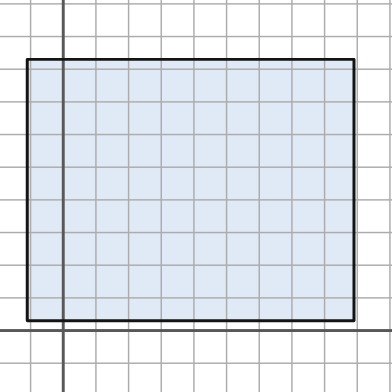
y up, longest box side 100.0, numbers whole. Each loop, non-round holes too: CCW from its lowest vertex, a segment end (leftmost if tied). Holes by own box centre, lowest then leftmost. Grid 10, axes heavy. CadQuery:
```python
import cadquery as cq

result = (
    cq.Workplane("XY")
    .moveTo(-11.0, 3.0)
    .lineTo(89.0, 3.0)
    .lineTo(89.0, 83.0)
    .lineTo(-11.0, 83.0)
    .close()
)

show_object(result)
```